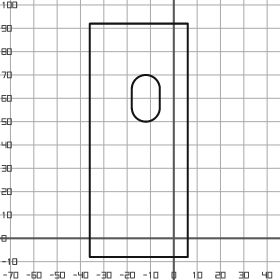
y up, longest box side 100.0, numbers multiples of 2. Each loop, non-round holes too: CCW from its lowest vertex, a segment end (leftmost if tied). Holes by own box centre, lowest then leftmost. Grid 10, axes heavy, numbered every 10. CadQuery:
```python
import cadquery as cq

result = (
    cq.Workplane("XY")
    .moveTo(-36.0, -8.0)
    .lineTo(6.0, -8.0)
    .lineTo(6.0, 92.0)
    .lineTo(-36.0, 92.0)
    .close()
    .moveTo(-18.0, 56.0)
    .threePointArc((-12.0, 50.0), (-6.0, 56.0))
    .lineTo(-6.0, 64.0)
    .threePointArc((-12.0, 70.0), (-18.0, 64.0))
    .close()
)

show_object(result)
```